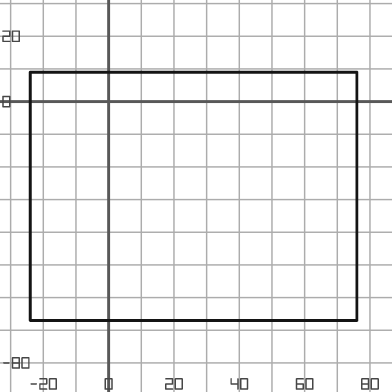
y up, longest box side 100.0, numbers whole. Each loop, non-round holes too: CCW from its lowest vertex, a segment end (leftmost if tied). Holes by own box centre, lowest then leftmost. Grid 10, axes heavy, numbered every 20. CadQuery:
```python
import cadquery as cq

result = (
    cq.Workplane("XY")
    .moveTo(-24.0, -67.0)
    .lineTo(76.0, -67.0)
    .lineTo(76.0, 9.0)
    .lineTo(-24.0, 9.0)
    .close()
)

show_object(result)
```